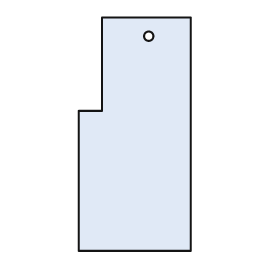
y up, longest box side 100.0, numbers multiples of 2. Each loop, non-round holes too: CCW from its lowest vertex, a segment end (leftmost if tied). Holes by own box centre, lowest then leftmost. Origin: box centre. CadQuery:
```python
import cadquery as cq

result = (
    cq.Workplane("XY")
    .moveTo(-24.0, -50.0)
    .lineTo(24.0, -50.0)
    .lineTo(24.0, 50.0)
    .lineTo(-14.0, 50.0)
    .lineTo(-14.0, 10.0)
    .lineTo(-24.0, 10.0)
    .close()
    .moveTo(6.0, 42.0)
    .circle(2.0)
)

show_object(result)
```